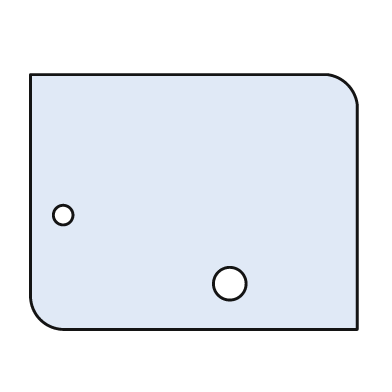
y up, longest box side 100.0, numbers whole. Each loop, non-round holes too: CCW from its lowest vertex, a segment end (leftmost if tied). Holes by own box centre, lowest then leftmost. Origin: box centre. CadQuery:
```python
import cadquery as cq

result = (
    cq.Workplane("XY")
    .moveTo(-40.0, -39.0)
    .lineTo(50.0, -39.0)
    .lineTo(50.0, 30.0)
    .threePointArc((47.0, 36.0), (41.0, 39.0))
    .lineTo(-50.0, 39.0)
    .lineTo(-50.0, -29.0)
    .threePointArc((-47.0, -36.0), (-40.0, -39.0))
    .close()
    .moveTo(11.0, -25.0)
    .circle(5.0)
    .moveTo(-40.0, -4.0)
    .circle(3.0)
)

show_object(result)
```